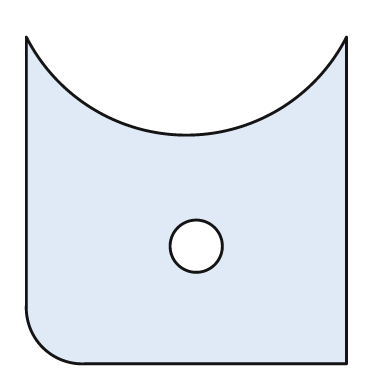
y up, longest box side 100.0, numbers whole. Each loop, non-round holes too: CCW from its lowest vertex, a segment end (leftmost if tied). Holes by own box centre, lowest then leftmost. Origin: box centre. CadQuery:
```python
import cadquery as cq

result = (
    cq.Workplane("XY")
    .moveTo(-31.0, -50.0)
    .lineTo(49.0, -50.0)
    .lineTo(49.0, 50.0)
    .threePointArc((0.0, 20.0), (-49.0, 50.0))
    .lineTo(-49.0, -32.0)
    .threePointArc((-44.0, -45.0), (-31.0, -50.0))
    .close()
    .moveTo(3.0, -14.0)
    .circle(8.0)
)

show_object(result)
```